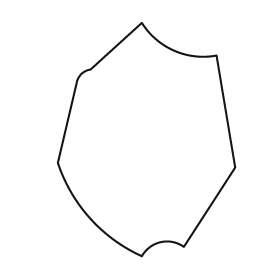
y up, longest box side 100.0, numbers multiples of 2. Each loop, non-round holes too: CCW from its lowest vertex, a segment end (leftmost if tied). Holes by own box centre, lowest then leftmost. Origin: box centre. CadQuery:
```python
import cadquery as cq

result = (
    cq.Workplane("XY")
    .moveTo(-2.0, -50.0)
    .threePointArc((6.0, -44.0), (16.0, -46.0))
    .lineTo(38.0, -12.0)
    .lineTo(30.0, 36.0)
    .threePointArc((12.0, 38.0), (-2.0, 50.0))
    .lineTo(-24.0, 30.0)
    .threePointArc((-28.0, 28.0), (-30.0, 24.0))
    .lineTo(-38.0, -10.0)
    .threePointArc((-24.0, -34.0), (-2.0, -50.0))
    .close()
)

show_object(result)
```